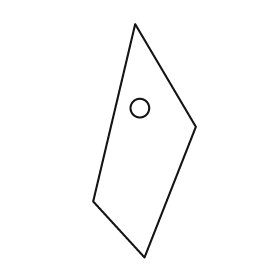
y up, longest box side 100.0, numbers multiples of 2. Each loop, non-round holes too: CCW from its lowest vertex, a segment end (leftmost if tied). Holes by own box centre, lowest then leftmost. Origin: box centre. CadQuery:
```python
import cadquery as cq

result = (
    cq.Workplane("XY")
    .moveTo(0.0, -50.0)
    .lineTo(22.0, 6.0)
    .lineTo(-4.0, 50.0)
    .lineTo(-22.0, -26.0)
    .close()
    .moveTo(-2.0, 14.0)
    .circle(4.0)
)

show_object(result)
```